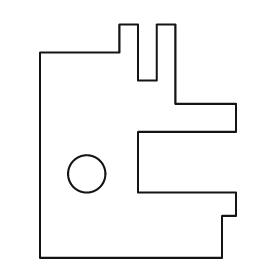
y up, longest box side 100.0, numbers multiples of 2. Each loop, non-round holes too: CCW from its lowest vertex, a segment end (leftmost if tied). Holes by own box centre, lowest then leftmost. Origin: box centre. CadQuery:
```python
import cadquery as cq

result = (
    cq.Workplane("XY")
    .moveTo(-42.0, -50.0)
    .lineTo(36.0, -50.0)
    .lineTo(36.0, -32.0)
    .lineTo(42.0, -32.0)
    .lineTo(42.0, -22.0)
    .lineTo(0.0, -22.0)
    .lineTo(0.0, 4.0)
    .lineTo(42.0, 4.0)
    .lineTo(42.0, 16.0)
    .lineTo(16.0, 16.0)
    .lineTo(16.0, 50.0)
    .lineTo(8.0, 50.0)
    .lineTo(8.0, 26.0)
    .lineTo(0.0, 26.0)
    .lineTo(0.0, 50.0)
    .lineTo(-8.0, 50.0)
    .lineTo(-8.0, 38.0)
    .lineTo(-42.0, 38.0)
    .close()
    .moveTo(-22.0, -14.0)
    .circle(8.0)
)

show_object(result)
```